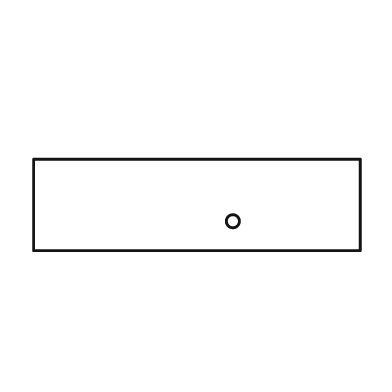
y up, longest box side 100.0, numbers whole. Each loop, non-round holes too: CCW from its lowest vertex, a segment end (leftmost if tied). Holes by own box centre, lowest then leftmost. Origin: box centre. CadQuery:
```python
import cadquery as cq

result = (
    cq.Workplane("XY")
    .moveTo(-50.0, -14.0)
    .lineTo(50.0, -14.0)
    .lineTo(50.0, 14.0)
    .lineTo(-50.0, 14.0)
    .close()
    .moveTo(11.0, -5.0)
    .circle(2.0)
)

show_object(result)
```